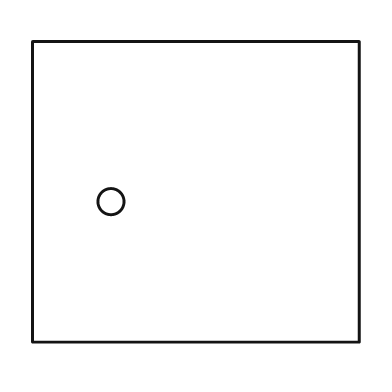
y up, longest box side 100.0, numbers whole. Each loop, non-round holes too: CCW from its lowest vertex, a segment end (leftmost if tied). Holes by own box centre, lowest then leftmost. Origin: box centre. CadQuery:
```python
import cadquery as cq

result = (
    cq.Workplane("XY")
    .moveTo(-50.0, -46.0)
    .lineTo(50.0, -46.0)
    .lineTo(50.0, 46.0)
    .lineTo(-50.0, 46.0)
    .close()
    .moveTo(-26.0, -3.0)
    .circle(4.0)
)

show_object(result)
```